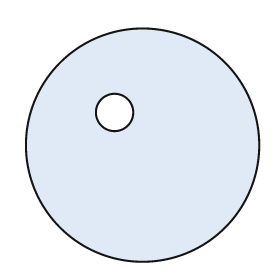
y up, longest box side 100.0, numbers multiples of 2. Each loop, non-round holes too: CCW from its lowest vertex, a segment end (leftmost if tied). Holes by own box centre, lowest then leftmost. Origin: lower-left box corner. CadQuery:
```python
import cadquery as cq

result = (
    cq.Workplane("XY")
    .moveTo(50.0, 50.0)
    .circle(50.0)
    .moveTo(38.0, 64.0)
    .circle(8.0)
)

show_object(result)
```